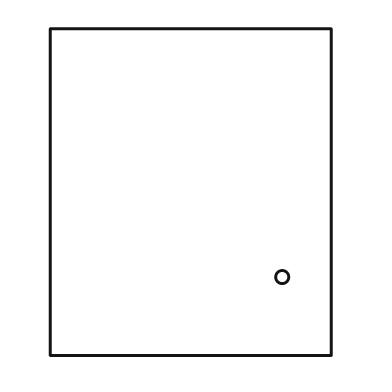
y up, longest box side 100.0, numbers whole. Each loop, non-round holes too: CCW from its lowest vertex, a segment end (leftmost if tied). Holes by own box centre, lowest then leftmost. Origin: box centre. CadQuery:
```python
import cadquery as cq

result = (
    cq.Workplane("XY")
    .moveTo(-43.0, -50.0)
    .lineTo(43.0, -50.0)
    .lineTo(43.0, 50.0)
    .lineTo(-43.0, 50.0)
    .close()
    .moveTo(28.0, -26.0)
    .circle(2.0)
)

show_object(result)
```